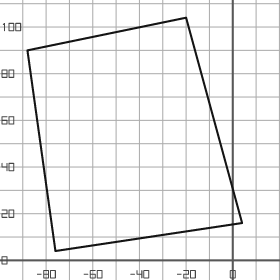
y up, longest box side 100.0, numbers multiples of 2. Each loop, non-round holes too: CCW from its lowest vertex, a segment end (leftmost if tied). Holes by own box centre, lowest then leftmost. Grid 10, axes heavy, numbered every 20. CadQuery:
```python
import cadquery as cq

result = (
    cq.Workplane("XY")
    .moveTo(-76.0, 4.0)
    .lineTo(4.0, 16.0)
    .lineTo(-20.0, 104.0)
    .lineTo(-88.0, 90.0)
    .close()
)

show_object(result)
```